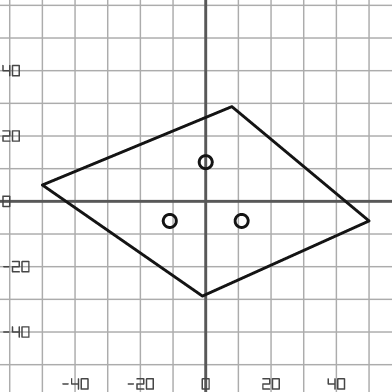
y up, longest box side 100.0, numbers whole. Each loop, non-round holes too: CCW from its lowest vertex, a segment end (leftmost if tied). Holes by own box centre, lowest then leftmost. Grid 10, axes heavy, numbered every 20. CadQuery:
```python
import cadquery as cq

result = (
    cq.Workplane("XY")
    .moveTo(-1.0, -29.0)
    .lineTo(50.0, -6.0)
    .lineTo(8.0, 29.0)
    .lineTo(-50.0, 5.0)
    .close()
    .moveTo(-11.0, -6.0)
    .circle(2.0)
    .moveTo(11.0, -6.0)
    .circle(2.0)
    .moveTo(0.0, 12.0)
    .circle(2.0)
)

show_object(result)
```